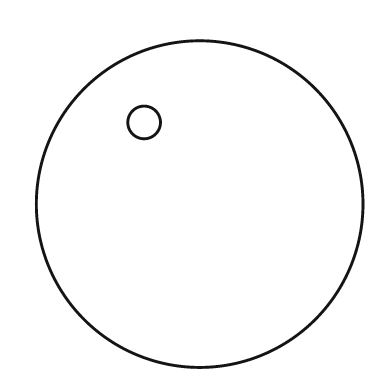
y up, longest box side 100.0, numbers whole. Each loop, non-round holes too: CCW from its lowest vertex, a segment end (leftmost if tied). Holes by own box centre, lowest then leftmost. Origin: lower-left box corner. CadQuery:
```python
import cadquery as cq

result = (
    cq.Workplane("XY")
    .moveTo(50.0, 50.0)
    .circle(50.0)
    .moveTo(33.0, 75.0)
    .circle(5.0)
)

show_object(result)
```